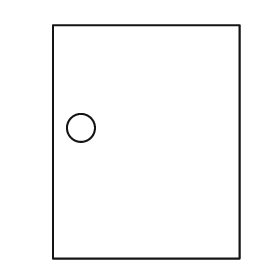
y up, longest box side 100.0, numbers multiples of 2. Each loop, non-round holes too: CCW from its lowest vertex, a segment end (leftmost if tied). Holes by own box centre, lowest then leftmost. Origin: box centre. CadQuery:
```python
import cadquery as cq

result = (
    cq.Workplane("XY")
    .moveTo(-40.0, -50.0)
    .lineTo(40.0, -50.0)
    .lineTo(40.0, 50.0)
    .lineTo(-40.0, 50.0)
    .close()
    .moveTo(-28.0, 6.0)
    .circle(6.0)
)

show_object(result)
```